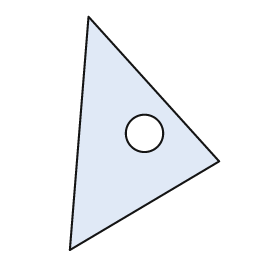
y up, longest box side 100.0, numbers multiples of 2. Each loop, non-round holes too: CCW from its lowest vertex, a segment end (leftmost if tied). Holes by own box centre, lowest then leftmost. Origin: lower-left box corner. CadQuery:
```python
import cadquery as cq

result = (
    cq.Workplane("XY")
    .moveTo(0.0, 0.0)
    .lineTo(64.0, 38.0)
    .lineTo(8.0, 100.0)
    .close()
    .moveTo(32.0, 50.0)
    .circle(8.0)
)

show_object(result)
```